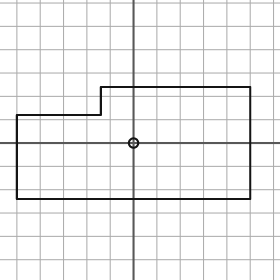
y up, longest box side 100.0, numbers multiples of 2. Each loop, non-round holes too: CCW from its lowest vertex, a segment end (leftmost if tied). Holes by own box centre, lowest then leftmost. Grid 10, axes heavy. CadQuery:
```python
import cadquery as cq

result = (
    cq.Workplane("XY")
    .moveTo(-50.0, -24.0)
    .lineTo(50.0, -24.0)
    .lineTo(50.0, 24.0)
    .lineTo(-14.0, 24.0)
    .lineTo(-14.0, 12.0)
    .lineTo(-50.0, 12.0)
    .close()
    .moveTo(0.0, 0.0)
    .circle(2.0)
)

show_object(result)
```